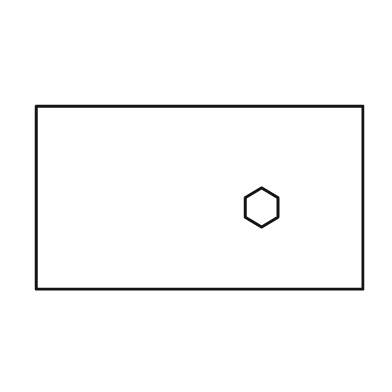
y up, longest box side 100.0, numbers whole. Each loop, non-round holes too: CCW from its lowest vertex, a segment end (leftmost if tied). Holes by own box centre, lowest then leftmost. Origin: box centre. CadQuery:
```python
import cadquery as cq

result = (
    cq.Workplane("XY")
    .moveTo(-50.0, -28.0)
    .lineTo(50.0, -28.0)
    .lineTo(50.0, 28.0)
    .lineTo(-50.0, 28.0)
    .close()
    .moveTo(19.0, -9.0)
    .lineTo(24.0, -6.0)
    .lineTo(24.0, 0.0)
    .lineTo(19.0, 3.0)
    .lineTo(14.0, 0.0)
    .lineTo(14.0, -6.0)
    .close()
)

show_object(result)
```